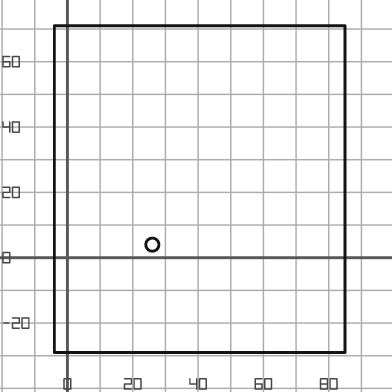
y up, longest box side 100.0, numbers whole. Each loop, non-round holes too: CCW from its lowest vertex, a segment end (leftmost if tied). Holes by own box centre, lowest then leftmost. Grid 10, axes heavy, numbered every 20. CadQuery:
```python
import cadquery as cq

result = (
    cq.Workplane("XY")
    .moveTo(-4.0, -29.0)
    .lineTo(85.0, -29.0)
    .lineTo(85.0, 71.0)
    .lineTo(-4.0, 71.0)
    .close()
    .moveTo(26.0, 4.0)
    .circle(2.0)
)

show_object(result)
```